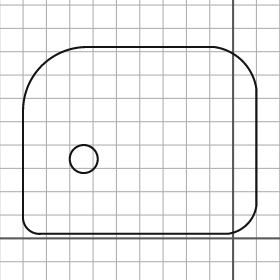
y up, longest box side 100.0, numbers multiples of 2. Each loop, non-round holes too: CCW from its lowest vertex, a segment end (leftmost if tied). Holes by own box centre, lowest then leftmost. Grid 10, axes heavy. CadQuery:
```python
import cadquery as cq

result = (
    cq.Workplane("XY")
    .moveTo(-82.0, 2.0)
    .lineTo(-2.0, 2.0)
    .threePointArc((6.0, 6.0), (10.0, 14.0))
    .lineTo(10.0, 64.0)
    .threePointArc((4.0, 76.0), (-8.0, 82.0))
    .lineTo(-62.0, 82.0)
    .threePointArc((-82.0, 74.0), (-90.0, 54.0))
    .lineTo(-90.0, 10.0)
    .threePointArc((-88.0, 4.0), (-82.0, 2.0))
    .close()
    .moveTo(-64.0, 34.0)
    .circle(6.0)
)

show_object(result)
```